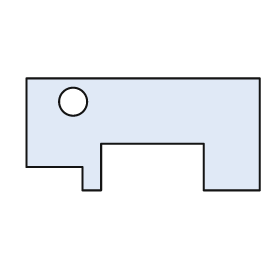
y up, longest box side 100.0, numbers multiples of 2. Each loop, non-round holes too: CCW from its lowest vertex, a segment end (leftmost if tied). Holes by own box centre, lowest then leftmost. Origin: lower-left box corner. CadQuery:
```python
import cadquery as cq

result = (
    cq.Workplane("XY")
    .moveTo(24.0, 0.0)
    .lineTo(32.0, 0.0)
    .lineTo(32.0, 20.0)
    .lineTo(76.0, 20.0)
    .lineTo(76.0, 0.0)
    .lineTo(100.0, 0.0)
    .lineTo(100.0, 48.0)
    .lineTo(0.0, 48.0)
    .lineTo(0.0, 10.0)
    .lineTo(24.0, 10.0)
    .close()
    .moveTo(20.0, 38.0)
    .circle(6.0)
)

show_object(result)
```